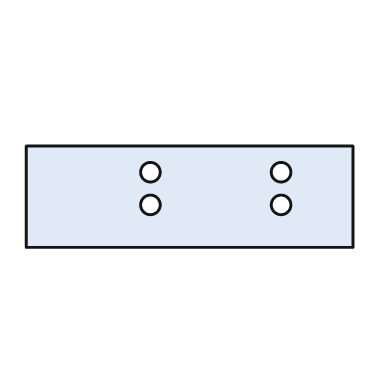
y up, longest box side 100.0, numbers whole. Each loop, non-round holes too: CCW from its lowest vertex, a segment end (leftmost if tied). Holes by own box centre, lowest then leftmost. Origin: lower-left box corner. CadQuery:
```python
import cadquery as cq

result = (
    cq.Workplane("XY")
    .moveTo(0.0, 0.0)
    .lineTo(100.0, 0.0)
    .lineTo(100.0, 31.0)
    .lineTo(0.0, 31.0)
    .close()
    .moveTo(38.0, 13.0)
    .circle(3.0)
    .moveTo(78.0, 13.0)
    .circle(3.0)
    .moveTo(38.0, 23.0)
    .circle(3.0)
    .moveTo(78.0, 23.0)
    .circle(3.0)
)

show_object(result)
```